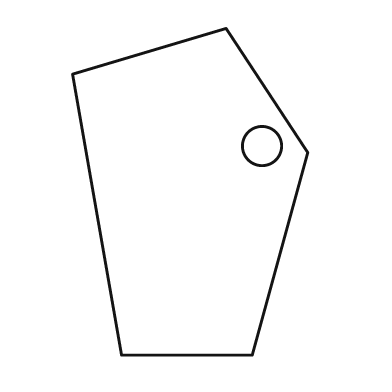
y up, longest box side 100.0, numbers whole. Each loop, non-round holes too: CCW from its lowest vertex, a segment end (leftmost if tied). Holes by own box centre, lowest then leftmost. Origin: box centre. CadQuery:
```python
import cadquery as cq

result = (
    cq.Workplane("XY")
    .moveTo(-21.0, -50.0)
    .lineTo(19.0, -50.0)
    .lineTo(36.0, 12.0)
    .lineTo(11.0, 50.0)
    .lineTo(-36.0, 36.0)
    .close()
    .moveTo(22.0, 14.0)
    .circle(6.0)
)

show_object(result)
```